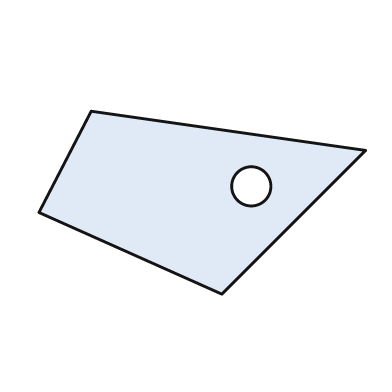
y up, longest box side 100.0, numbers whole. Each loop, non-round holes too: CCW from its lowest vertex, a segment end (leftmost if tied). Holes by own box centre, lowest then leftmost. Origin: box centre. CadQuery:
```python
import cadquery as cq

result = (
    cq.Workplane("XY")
    .moveTo(6.0, -28.0)
    .lineTo(50.0, 16.0)
    .lineTo(-34.0, 28.0)
    .lineTo(-50.0, -3.0)
    .close()
    .moveTo(15.0, 5.0)
    .circle(6.0)
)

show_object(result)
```